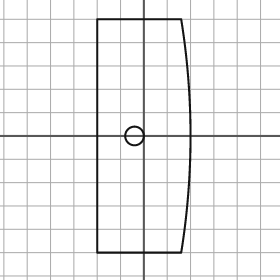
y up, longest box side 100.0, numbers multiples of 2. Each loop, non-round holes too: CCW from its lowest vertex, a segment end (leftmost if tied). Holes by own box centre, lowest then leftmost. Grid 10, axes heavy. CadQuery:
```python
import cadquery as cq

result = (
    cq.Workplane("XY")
    .moveTo(-20.0, -50.0)
    .lineTo(16.0, -50.0)
    .threePointArc((20.0, 0.0), (16.0, 50.0))
    .lineTo(-20.0, 50.0)
    .close()
    .moveTo(-4.0, 0.0)
    .circle(4.0)
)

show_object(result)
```